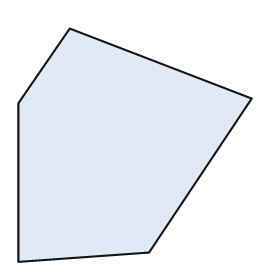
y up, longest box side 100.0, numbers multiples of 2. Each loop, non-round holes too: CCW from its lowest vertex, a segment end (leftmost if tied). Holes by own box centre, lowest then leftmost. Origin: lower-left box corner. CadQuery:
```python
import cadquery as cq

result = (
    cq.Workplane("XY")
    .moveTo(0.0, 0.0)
    .lineTo(56.0, 4.0)
    .lineTo(100.0, 70.0)
    .lineTo(22.0, 100.0)
    .lineTo(0.0, 68.0)
    .close()
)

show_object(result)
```